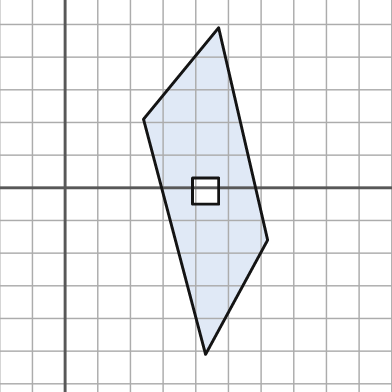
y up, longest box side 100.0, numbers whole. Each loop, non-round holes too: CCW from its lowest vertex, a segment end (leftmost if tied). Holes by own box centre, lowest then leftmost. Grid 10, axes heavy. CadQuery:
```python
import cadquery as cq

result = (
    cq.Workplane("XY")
    .moveTo(43.0, -51.0)
    .lineTo(62.0, -16.0)
    .lineTo(47.0, 49.0)
    .lineTo(24.0, 21.0)
    .close()
    .moveTo(39.0, -5.0)
    .lineTo(47.0, -5.0)
    .lineTo(47.0, 3.0)
    .lineTo(39.0, 3.0)
    .close()
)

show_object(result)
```